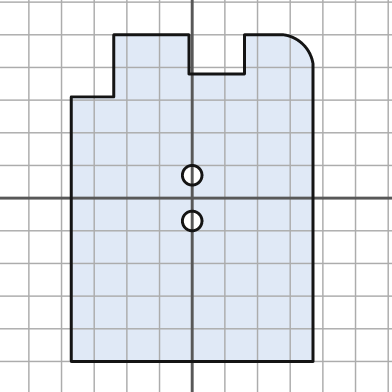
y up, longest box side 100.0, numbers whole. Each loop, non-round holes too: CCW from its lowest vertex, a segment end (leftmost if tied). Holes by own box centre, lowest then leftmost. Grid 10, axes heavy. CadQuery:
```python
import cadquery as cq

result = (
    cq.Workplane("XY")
    .moveTo(-37.0, -50.0)
    .lineTo(37.0, -50.0)
    .lineTo(37.0, 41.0)
    .threePointArc((34.0, 47.0), (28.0, 50.0))
    .lineTo(16.0, 50.0)
    .lineTo(16.0, 38.0)
    .lineTo(-1.0, 38.0)
    .lineTo(-1.0, 50.0)
    .lineTo(-24.0, 50.0)
    .lineTo(-24.0, 31.0)
    .lineTo(-37.0, 31.0)
    .close()
    .moveTo(0.0, -7.0)
    .circle(3.0)
    .moveTo(0.0, 7.0)
    .circle(3.0)
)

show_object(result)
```